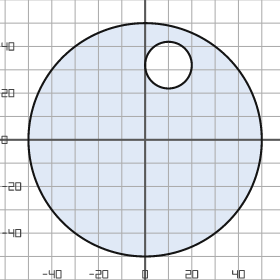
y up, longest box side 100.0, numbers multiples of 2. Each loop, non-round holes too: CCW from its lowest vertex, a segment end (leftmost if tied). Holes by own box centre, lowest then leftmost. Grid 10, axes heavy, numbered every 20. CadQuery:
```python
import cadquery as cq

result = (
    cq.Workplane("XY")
    .moveTo(0.0, 0.0)
    .circle(50.0)
    .moveTo(10.0, 32.0)
    .circle(10.0)
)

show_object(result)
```